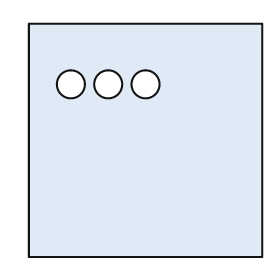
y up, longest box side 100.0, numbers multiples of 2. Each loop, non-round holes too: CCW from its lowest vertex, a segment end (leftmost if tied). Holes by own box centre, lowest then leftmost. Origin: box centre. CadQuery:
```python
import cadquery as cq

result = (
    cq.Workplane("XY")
    .moveTo(-50.0, -50.0)
    .lineTo(50.0, -50.0)
    .lineTo(50.0, 50.0)
    .lineTo(-50.0, 50.0)
    .close()
    .moveTo(-32.0, 24.0)
    .circle(6.0)
    .moveTo(-16.0, 24.0)
    .circle(6.0)
    .moveTo(0.0, 24.0)
    .circle(6.0)
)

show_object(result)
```